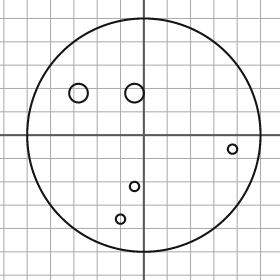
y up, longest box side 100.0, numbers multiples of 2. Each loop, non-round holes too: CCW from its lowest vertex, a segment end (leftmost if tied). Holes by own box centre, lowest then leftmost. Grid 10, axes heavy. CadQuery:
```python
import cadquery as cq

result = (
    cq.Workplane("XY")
    .moveTo(0.0, 0.0)
    .circle(50.0)
    .moveTo(-10.0, -36.0)
    .circle(2.0)
    .moveTo(-4.0, -22.0)
    .circle(2.0)
    .moveTo(38.0, -6.0)
    .circle(2.0)
    .moveTo(-28.0, 18.0)
    .circle(4.0)
    .moveTo(-4.0, 18.0)
    .circle(4.0)
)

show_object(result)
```